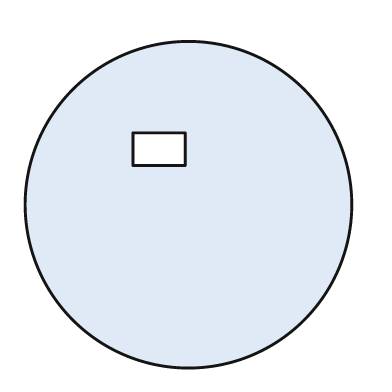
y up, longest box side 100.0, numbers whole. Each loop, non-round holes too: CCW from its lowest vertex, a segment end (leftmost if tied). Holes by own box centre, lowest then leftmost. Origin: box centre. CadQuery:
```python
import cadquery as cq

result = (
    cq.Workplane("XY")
    .moveTo(0.0, 0.0)
    .circle(50.0)
    .moveTo(-17.0, 12.0)
    .lineTo(-1.0, 12.0)
    .lineTo(-1.0, 22.0)
    .lineTo(-17.0, 22.0)
    .close()
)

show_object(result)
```